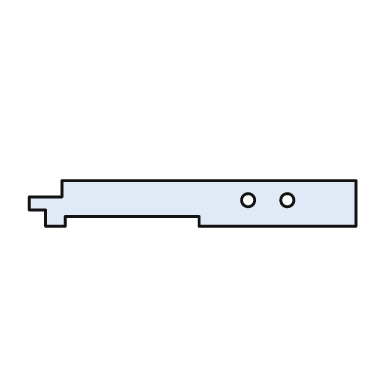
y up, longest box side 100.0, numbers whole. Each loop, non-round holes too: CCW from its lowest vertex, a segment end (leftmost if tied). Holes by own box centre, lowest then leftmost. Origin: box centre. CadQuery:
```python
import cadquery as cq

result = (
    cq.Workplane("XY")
    .moveTo(-45.0, -7.0)
    .lineTo(-39.0, -7.0)
    .lineTo(-39.0, -4.0)
    .lineTo(2.0, -4.0)
    .lineTo(2.0, -7.0)
    .lineTo(50.0, -7.0)
    .lineTo(50.0, 7.0)
    .lineTo(-40.0, 7.0)
    .lineTo(-40.0, 2.0)
    .lineTo(-50.0, 2.0)
    .lineTo(-50.0, -2.0)
    .lineTo(-45.0, -2.0)
    .close()
    .moveTo(17.0, 1.0)
    .circle(2.0)
    .moveTo(29.0, 1.0)
    .circle(2.0)
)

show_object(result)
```